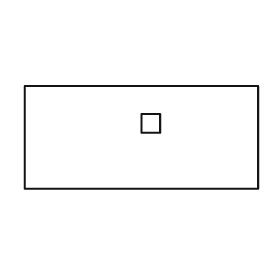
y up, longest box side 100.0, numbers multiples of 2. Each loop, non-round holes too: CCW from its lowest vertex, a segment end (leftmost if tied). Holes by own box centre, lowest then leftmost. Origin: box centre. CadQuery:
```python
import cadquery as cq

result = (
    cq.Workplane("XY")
    .moveTo(-50.0, -22.0)
    .lineTo(50.0, -22.0)
    .lineTo(50.0, 22.0)
    .lineTo(-50.0, 22.0)
    .close()
    .moveTo(0.0, 2.0)
    .lineTo(8.0, 2.0)
    .lineTo(8.0, 10.0)
    .lineTo(0.0, 10.0)
    .close()
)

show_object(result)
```